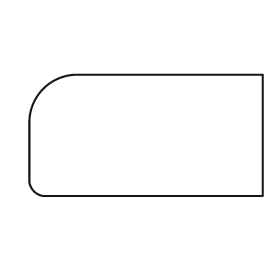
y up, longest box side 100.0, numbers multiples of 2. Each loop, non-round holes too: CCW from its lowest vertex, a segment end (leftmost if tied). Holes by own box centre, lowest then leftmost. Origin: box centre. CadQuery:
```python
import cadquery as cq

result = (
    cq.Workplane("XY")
    .moveTo(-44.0, -26.0)
    .lineTo(50.0, -26.0)
    .lineTo(50.0, 26.0)
    .lineTo(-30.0, 26.0)
    .threePointArc((-44.0, 20.0), (-50.0, 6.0))
    .lineTo(-50.0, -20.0)
    .threePointArc((-48.0, -24.0), (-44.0, -26.0))
    .close()
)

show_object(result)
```